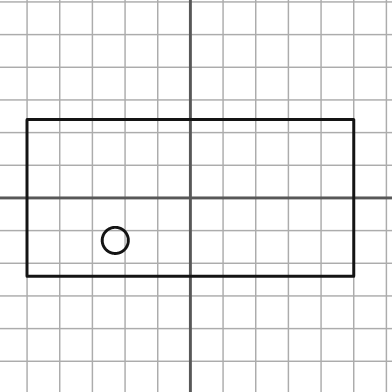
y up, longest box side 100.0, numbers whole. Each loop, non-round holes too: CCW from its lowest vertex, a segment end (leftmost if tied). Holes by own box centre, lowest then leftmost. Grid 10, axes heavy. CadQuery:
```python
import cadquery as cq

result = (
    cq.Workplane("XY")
    .moveTo(-50.0, -24.0)
    .lineTo(50.0, -24.0)
    .lineTo(50.0, 24.0)
    .lineTo(-50.0, 24.0)
    .close()
    .moveTo(-23.0, -13.0)
    .circle(4.0)
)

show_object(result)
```